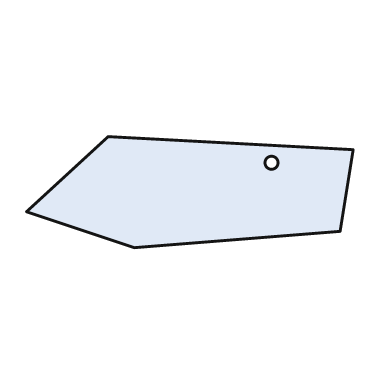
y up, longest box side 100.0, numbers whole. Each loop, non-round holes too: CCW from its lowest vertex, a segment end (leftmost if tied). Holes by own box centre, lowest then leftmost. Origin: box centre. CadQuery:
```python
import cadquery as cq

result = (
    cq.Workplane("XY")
    .moveTo(-17.0, -17.0)
    .lineTo(46.0, -12.0)
    .lineTo(50.0, 13.0)
    .lineTo(-25.0, 17.0)
    .lineTo(-50.0, -6.0)
    .close()
    .moveTo(25.0, 9.0)
    .circle(2.0)
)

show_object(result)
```